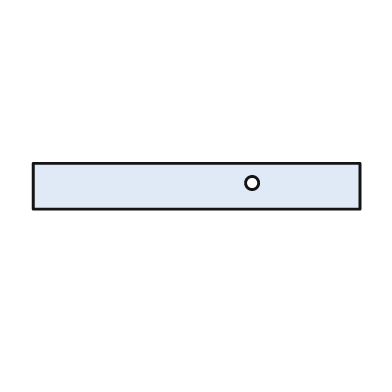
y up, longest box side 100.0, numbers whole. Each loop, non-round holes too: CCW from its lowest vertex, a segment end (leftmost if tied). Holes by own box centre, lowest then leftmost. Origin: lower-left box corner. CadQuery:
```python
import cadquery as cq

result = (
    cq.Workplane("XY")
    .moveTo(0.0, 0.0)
    .lineTo(100.0, 0.0)
    .lineTo(100.0, 14.0)
    .lineTo(0.0, 14.0)
    .close()
    .moveTo(67.0, 8.0)
    .circle(2.0)
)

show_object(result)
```